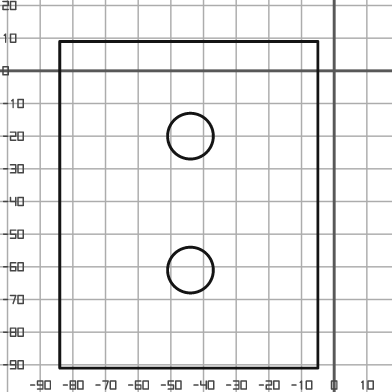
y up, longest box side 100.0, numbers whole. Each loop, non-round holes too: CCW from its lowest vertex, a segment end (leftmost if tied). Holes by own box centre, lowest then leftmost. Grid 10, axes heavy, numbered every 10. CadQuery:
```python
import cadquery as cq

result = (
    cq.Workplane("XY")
    .moveTo(-84.0, -91.0)
    .lineTo(-5.0, -91.0)
    .lineTo(-5.0, 9.0)
    .lineTo(-84.0, 9.0)
    .close()
    .moveTo(-44.0, -61.0)
    .circle(7.0)
    .moveTo(-44.0, -20.0)
    .circle(7.0)
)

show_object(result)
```